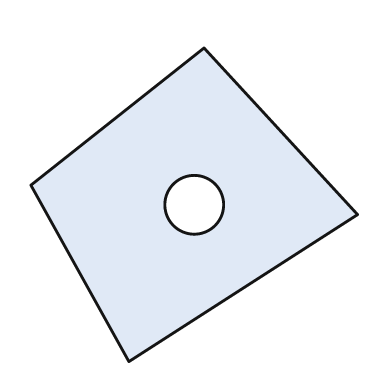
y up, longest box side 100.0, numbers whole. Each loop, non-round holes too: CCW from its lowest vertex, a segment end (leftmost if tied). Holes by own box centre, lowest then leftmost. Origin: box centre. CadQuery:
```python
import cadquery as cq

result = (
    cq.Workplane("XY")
    .moveTo(-20.0, -48.0)
    .lineTo(50.0, -3.0)
    .lineTo(3.0, 48.0)
    .lineTo(-50.0, 6.0)
    .close()
    .moveTo(0.0, 0.0)
    .circle(9.0)
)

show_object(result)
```